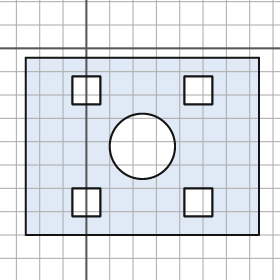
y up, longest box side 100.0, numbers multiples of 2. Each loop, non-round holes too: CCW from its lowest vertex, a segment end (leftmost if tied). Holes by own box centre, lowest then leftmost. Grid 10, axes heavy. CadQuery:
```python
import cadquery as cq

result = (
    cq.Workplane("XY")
    .moveTo(-26.0, -80.0)
    .lineTo(74.0, -80.0)
    .lineTo(74.0, -4.0)
    .lineTo(-26.0, -4.0)
    .close()
    .moveTo(-6.0, -72.0)
    .lineTo(6.0, -72.0)
    .lineTo(6.0, -60.0)
    .lineTo(-6.0, -60.0)
    .close()
    .moveTo(42.0, -72.0)
    .lineTo(54.0, -72.0)
    .lineTo(54.0, -60.0)
    .lineTo(42.0, -60.0)
    .close()
    .moveTo(24.0, -42.0)
    .circle(14.0)
    .moveTo(-6.0, -24.0)
    .lineTo(6.0, -24.0)
    .lineTo(6.0, -12.0)
    .lineTo(-6.0, -12.0)
    .close()
    .moveTo(42.0, -24.0)
    .lineTo(54.0, -24.0)
    .lineTo(54.0, -12.0)
    .lineTo(42.0, -12.0)
    .close()
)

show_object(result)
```